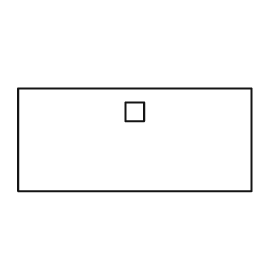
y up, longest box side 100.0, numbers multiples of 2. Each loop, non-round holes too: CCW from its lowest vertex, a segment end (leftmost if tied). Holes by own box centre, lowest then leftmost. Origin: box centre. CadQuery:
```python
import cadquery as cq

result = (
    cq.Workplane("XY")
    .moveTo(-50.0, -22.0)
    .lineTo(50.0, -22.0)
    .lineTo(50.0, 22.0)
    .lineTo(-50.0, 22.0)
    .close()
    .moveTo(-4.0, 8.0)
    .lineTo(4.0, 8.0)
    .lineTo(4.0, 16.0)
    .lineTo(-4.0, 16.0)
    .close()
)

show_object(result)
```